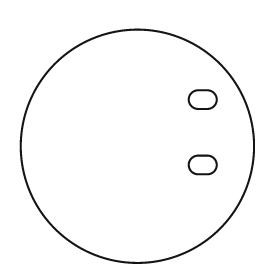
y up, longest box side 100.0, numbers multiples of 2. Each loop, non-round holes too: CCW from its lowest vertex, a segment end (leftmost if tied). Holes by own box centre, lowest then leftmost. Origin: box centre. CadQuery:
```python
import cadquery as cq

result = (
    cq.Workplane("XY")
    .moveTo(0.0, 0.0)
    .circle(50.0)
    .moveTo(26.0, -12.0)
    .lineTo(30.0, -12.0)
    .threePointArc((34.0, -8.0), (30.0, -4.0))
    .lineTo(26.0, -4.0)
    .threePointArc((22.0, -8.0), (26.0, -12.0))
    .close()
    .moveTo(26.0, 16.0)
    .lineTo(30.0, 16.0)
    .threePointArc((34.0, 20.0), (30.0, 24.0))
    .lineTo(26.0, 24.0)
    .threePointArc((22.0, 20.0), (26.0, 16.0))
    .close()
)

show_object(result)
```